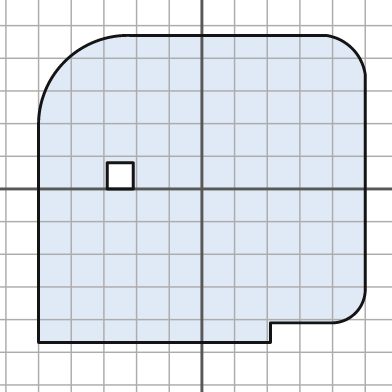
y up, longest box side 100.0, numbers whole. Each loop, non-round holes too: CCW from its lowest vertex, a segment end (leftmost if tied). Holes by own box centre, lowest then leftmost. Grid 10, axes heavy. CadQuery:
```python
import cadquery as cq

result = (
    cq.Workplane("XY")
    .moveTo(-50.0, -47.0)
    .lineTo(21.0, -47.0)
    .lineTo(21.0, -41.0)
    .lineTo(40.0, -41.0)
    .threePointArc((47.0, -38.0), (50.0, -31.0))
    .lineTo(50.0, 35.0)
    .threePointArc((46.0, 43.0), (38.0, 47.0))
    .lineTo(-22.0, 47.0)
    .threePointArc((-42.0, 39.0), (-50.0, 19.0))
    .close()
    .moveTo(-29.0, 0.0)
    .lineTo(-21.0, 0.0)
    .lineTo(-21.0, 8.0)
    .lineTo(-29.0, 8.0)
    .close()
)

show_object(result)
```